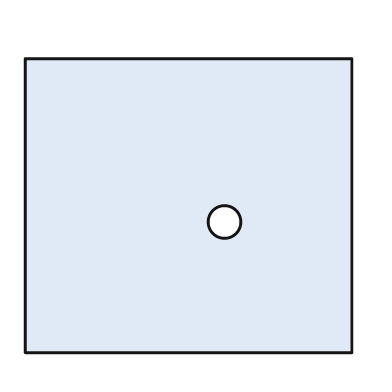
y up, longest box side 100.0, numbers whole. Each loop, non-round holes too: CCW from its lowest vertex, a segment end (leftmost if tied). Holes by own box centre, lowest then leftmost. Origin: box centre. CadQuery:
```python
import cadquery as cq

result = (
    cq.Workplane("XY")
    .moveTo(-50.0, -45.0)
    .lineTo(50.0, -45.0)
    .lineTo(50.0, 45.0)
    .lineTo(-50.0, 45.0)
    .close()
    .moveTo(11.0, -5.0)
    .circle(5.0)
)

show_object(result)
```